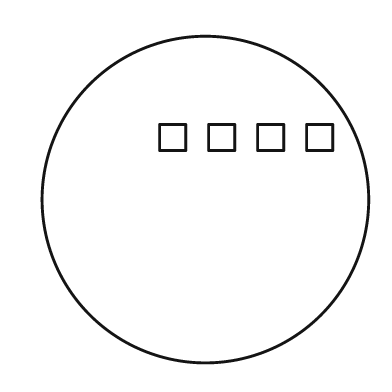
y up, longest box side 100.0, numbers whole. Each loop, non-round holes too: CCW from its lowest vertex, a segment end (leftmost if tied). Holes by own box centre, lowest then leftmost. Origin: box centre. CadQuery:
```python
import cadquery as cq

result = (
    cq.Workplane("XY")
    .moveTo(0.0, 0.0)
    .circle(50.0)
    .moveTo(-14.0, 15.0)
    .lineTo(-6.0, 15.0)
    .lineTo(-6.0, 23.0)
    .lineTo(-14.0, 23.0)
    .close()
    .moveTo(1.0, 15.0)
    .lineTo(9.0, 15.0)
    .lineTo(9.0, 23.0)
    .lineTo(1.0, 23.0)
    .close()
    .moveTo(16.0, 15.0)
    .lineTo(24.0, 15.0)
    .lineTo(24.0, 23.0)
    .lineTo(16.0, 23.0)
    .close()
    .moveTo(31.0, 15.0)
    .lineTo(39.0, 15.0)
    .lineTo(39.0, 23.0)
    .lineTo(31.0, 23.0)
    .close()
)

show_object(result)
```